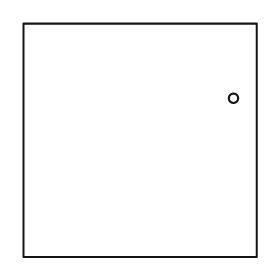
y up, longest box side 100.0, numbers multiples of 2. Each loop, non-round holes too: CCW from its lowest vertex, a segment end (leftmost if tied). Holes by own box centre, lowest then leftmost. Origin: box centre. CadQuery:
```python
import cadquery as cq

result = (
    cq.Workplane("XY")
    .moveTo(-50.0, -50.0)
    .lineTo(50.0, -50.0)
    .lineTo(50.0, 50.0)
    .lineTo(-50.0, 50.0)
    .close()
    .moveTo(40.0, 18.0)
    .circle(2.0)
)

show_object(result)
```